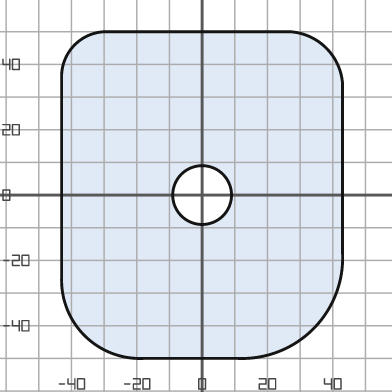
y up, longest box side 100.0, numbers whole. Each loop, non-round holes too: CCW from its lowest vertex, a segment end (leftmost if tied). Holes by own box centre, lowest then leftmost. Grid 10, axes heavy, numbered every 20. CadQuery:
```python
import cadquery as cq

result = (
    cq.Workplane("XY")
    .moveTo(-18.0, -50.0)
    .lineTo(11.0, -50.0)
    .threePointArc((34.0, -41.0), (43.0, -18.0))
    .lineTo(43.0, 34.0)
    .threePointArc((38.0, 45.0), (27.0, 50.0))
    .lineTo(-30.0, 50.0)
    .threePointArc((-39.0, 46.0), (-43.0, 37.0))
    .lineTo(-43.0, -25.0)
    .threePointArc((-36.0, -43.0), (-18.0, -50.0))
    .close()
    .moveTo(0.0, 0.0)
    .circle(9.0)
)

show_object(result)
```